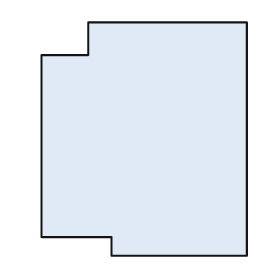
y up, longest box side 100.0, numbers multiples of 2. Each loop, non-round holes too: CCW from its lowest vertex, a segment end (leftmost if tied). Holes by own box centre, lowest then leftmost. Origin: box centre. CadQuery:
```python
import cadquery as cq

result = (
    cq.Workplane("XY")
    .moveTo(-14.0, -50.0)
    .lineTo(44.0, -50.0)
    .lineTo(44.0, 50.0)
    .lineTo(-24.0, 50.0)
    .lineTo(-24.0, 36.0)
    .lineTo(-44.0, 36.0)
    .lineTo(-44.0, -42.0)
    .lineTo(-14.0, -42.0)
    .close()
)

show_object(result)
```